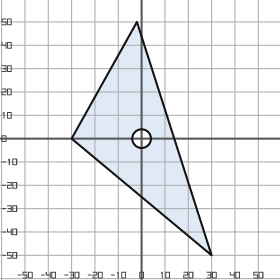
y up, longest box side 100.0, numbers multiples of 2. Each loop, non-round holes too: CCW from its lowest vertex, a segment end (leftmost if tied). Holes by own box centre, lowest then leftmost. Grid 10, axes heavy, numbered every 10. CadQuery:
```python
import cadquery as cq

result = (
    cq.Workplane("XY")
    .moveTo(30.0, -50.0)
    .lineTo(-2.0, 50.0)
    .lineTo(-30.0, 0.0)
    .close()
    .moveTo(0.0, 0.0)
    .circle(4.0)
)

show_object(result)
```